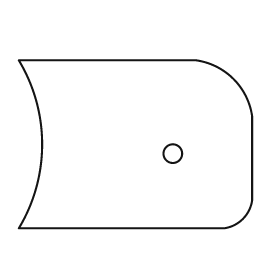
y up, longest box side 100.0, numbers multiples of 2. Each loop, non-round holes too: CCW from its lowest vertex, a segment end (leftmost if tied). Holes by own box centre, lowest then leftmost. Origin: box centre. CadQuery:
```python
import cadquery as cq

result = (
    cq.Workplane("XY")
    .moveTo(-50.0, -36.0)
    .lineTo(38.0, -36.0)
    .threePointArc((46.0, -32.0), (50.0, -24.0))
    .lineTo(50.0, 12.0)
    .threePointArc((42.0, 28.0), (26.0, 36.0))
    .lineTo(-50.0, 36.0)
    .threePointArc((-40.0, 0.0), (-50.0, -36.0))
    .close()
    .moveTo(16.0, -4.0)
    .circle(4.0)
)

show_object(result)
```